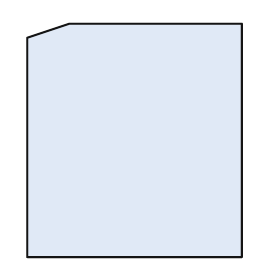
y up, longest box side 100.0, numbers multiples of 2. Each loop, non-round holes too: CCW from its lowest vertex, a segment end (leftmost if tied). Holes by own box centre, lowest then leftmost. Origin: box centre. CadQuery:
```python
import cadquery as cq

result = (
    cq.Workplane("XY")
    .moveTo(-46.0, -50.0)
    .lineTo(46.0, -50.0)
    .lineTo(46.0, 50.0)
    .lineTo(-28.0, 50.0)
    .lineTo(-46.0, 44.0)
    .close()
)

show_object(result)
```